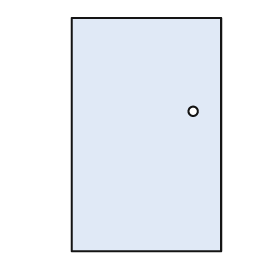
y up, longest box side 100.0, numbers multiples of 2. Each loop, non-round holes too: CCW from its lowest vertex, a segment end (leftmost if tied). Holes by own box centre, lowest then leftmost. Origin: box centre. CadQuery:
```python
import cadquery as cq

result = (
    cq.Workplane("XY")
    .moveTo(-32.0, -50.0)
    .lineTo(32.0, -50.0)
    .lineTo(32.0, 50.0)
    .lineTo(-32.0, 50.0)
    .close()
    .moveTo(20.0, 10.0)
    .circle(2.0)
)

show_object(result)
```